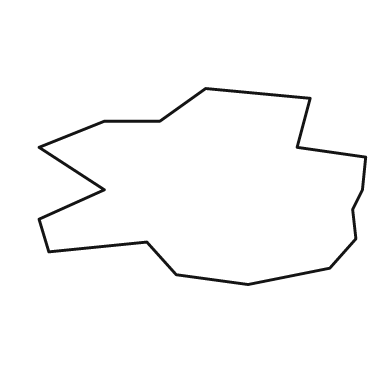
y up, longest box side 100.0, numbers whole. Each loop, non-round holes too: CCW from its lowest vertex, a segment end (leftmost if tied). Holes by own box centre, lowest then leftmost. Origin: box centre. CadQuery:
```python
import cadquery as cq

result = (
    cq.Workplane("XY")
    .moveTo(14.0, -30.0)
    .lineTo(39.0, -25.0)
    .lineTo(47.0, -16.0)
    .lineTo(46.0, -7.0)
    .lineTo(49.0, -1.0)
    .lineTo(50.0, 9.0)
    .lineTo(29.0, 12.0)
    .lineTo(33.0, 27.0)
    .lineTo(1.0, 30.0)
    .lineTo(-13.0, 20.0)
    .lineTo(-30.0, 20.0)
    .lineTo(-50.0, 12.0)
    .lineTo(-30.0, -1.0)
    .lineTo(-50.0, -10.0)
    .lineTo(-47.0, -20.0)
    .lineTo(-17.0, -17.0)
    .lineTo(-8.0, -27.0)
    .close()
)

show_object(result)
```